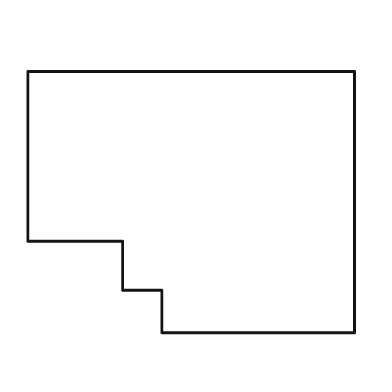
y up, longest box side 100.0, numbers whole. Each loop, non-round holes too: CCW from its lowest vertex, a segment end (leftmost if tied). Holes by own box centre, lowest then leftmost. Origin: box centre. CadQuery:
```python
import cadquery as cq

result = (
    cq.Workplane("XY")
    .moveTo(-9.0, -40.0)
    .lineTo(50.0, -40.0)
    .lineTo(50.0, 40.0)
    .lineTo(-50.0, 40.0)
    .lineTo(-50.0, -12.0)
    .lineTo(-21.0, -12.0)
    .lineTo(-21.0, -27.0)
    .lineTo(-9.0, -27.0)
    .close()
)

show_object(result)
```